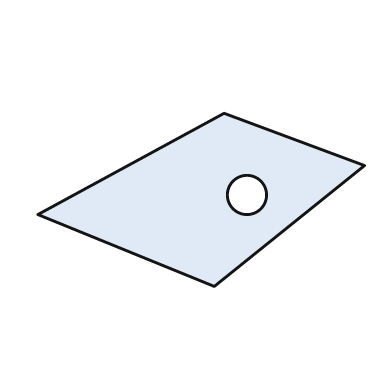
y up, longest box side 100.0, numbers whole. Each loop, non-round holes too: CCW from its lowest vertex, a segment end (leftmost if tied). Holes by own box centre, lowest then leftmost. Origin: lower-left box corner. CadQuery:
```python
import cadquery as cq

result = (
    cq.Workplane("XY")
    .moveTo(54.0, 0.0)
    .lineTo(100.0, 37.0)
    .lineTo(57.0, 53.0)
    .lineTo(0.0, 22.0)
    .close()
    .moveTo(64.0, 28.0)
    .circle(6.0)
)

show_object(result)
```